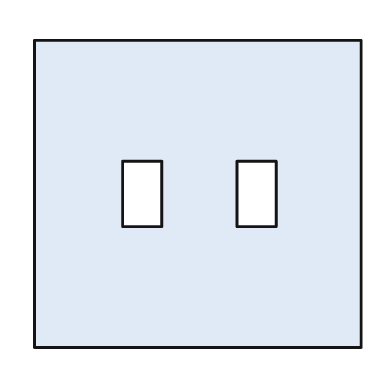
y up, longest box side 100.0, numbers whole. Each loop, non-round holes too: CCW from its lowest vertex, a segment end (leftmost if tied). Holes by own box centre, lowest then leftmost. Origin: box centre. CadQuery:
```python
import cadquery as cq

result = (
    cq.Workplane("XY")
    .moveTo(-50.0, -47.0)
    .lineTo(50.0, -47.0)
    .lineTo(50.0, 47.0)
    .lineTo(-50.0, 47.0)
    .close()
    .moveTo(-23.0, -10.0)
    .lineTo(-11.0, -10.0)
    .lineTo(-11.0, 10.0)
    .lineTo(-23.0, 10.0)
    .close()
    .moveTo(12.0, -10.0)
    .lineTo(24.0, -10.0)
    .lineTo(24.0, 10.0)
    .lineTo(12.0, 10.0)
    .close()
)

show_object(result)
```